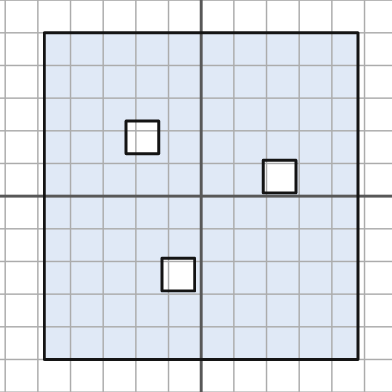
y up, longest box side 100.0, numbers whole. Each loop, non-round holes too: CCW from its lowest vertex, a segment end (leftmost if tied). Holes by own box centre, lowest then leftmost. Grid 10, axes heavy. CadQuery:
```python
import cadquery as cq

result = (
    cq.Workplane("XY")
    .moveTo(-48.0, -50.0)
    .lineTo(48.0, -50.0)
    .lineTo(48.0, 50.0)
    .lineTo(-48.0, 50.0)
    .close()
    .moveTo(-12.0, -29.0)
    .lineTo(-2.0, -29.0)
    .lineTo(-2.0, -19.0)
    .lineTo(-12.0, -19.0)
    .close()
    .moveTo(19.0, 1.0)
    .lineTo(29.0, 1.0)
    .lineTo(29.0, 11.0)
    .lineTo(19.0, 11.0)
    .close()
    .moveTo(-23.0, 13.0)
    .lineTo(-13.0, 13.0)
    .lineTo(-13.0, 23.0)
    .lineTo(-23.0, 23.0)
    .close()
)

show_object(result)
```